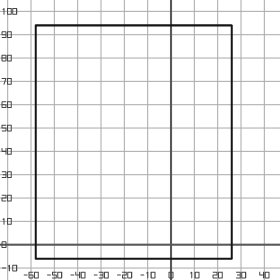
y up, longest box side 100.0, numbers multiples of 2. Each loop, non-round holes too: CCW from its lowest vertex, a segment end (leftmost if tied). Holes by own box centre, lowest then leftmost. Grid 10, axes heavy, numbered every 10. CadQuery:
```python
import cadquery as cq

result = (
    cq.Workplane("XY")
    .moveTo(-58.0, -6.0)
    .lineTo(26.0, -6.0)
    .lineTo(26.0, 94.0)
    .lineTo(-58.0, 94.0)
    .close()
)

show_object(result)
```